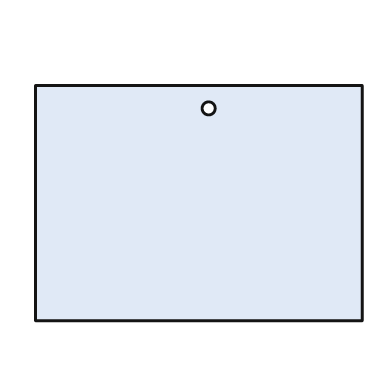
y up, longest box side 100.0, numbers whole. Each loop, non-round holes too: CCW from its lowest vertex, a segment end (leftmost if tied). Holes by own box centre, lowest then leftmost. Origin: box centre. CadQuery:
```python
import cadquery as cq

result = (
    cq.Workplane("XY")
    .moveTo(-50.0, -36.0)
    .lineTo(50.0, -36.0)
    .lineTo(50.0, 36.0)
    .lineTo(-50.0, 36.0)
    .close()
    .moveTo(3.0, 29.0)
    .circle(2.0)
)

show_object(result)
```